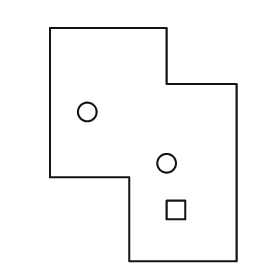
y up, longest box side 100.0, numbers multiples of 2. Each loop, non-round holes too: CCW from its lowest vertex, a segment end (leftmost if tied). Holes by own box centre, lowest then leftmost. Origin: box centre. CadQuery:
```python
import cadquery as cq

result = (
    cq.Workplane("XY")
    .moveTo(-6.0, -50.0)
    .lineTo(40.0, -50.0)
    .lineTo(40.0, 26.0)
    .lineTo(10.0, 26.0)
    .lineTo(10.0, 50.0)
    .lineTo(-40.0, 50.0)
    .lineTo(-40.0, -14.0)
    .lineTo(-6.0, -14.0)
    .close()
    .moveTo(10.0, -32.0)
    .lineTo(18.0, -32.0)
    .lineTo(18.0, -24.0)
    .lineTo(10.0, -24.0)
    .close()
    .moveTo(10.0, -8.0)
    .circle(4.0)
    .moveTo(-24.0, 14.0)
    .circle(4.0)
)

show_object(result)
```